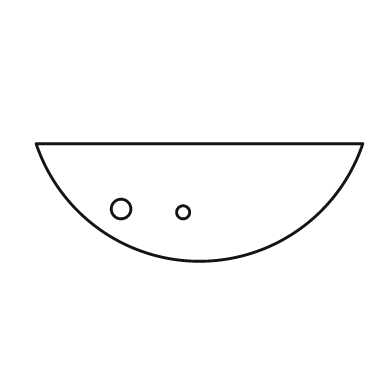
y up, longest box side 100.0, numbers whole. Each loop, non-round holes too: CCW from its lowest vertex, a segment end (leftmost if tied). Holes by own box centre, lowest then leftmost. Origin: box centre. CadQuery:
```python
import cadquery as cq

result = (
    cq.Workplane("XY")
    .moveTo(-50.0, 18.0)
    .threePointArc((0.0, -18.0), (50.0, 18.0))
    .close()
    .moveTo(-5.0, -3.0)
    .circle(2.0)
    .moveTo(-24.0, -2.0)
    .circle(3.0)
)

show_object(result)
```